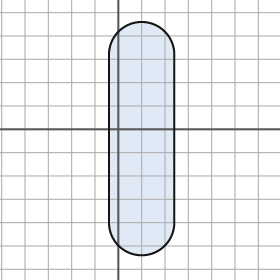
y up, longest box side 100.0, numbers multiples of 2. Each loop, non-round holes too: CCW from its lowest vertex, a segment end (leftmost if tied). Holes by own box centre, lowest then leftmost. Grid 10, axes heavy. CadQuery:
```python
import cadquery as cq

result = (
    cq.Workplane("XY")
    .moveTo(-4.0, -40.0)
    .threePointArc((10.0, -54.0), (24.0, -40.0))
    .lineTo(24.0, 32.0)
    .threePointArc((10.0, 46.0), (-4.0, 32.0))
    .close()
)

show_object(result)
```